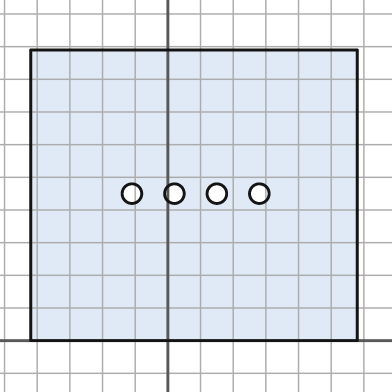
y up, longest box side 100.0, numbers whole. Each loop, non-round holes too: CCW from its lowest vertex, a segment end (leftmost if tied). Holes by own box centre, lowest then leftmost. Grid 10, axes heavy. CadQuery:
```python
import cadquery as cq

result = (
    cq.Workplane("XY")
    .moveTo(-42.0, 0.0)
    .lineTo(58.0, 0.0)
    .lineTo(58.0, 89.0)
    .lineTo(-42.0, 89.0)
    .close()
    .moveTo(-11.0, 45.0)
    .circle(3.0)
    .moveTo(2.0, 45.0)
    .circle(3.0)
    .moveTo(15.0, 45.0)
    .circle(3.0)
    .moveTo(28.0, 45.0)
    .circle(3.0)
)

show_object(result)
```